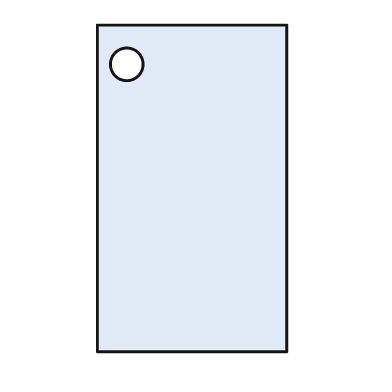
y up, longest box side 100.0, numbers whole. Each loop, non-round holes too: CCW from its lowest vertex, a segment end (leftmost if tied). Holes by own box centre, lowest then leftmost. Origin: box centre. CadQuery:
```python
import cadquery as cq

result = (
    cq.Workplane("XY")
    .moveTo(-29.0, -50.0)
    .lineTo(29.0, -50.0)
    .lineTo(29.0, 50.0)
    .lineTo(-29.0, 50.0)
    .close()
    .moveTo(-20.0, 38.0)
    .circle(5.0)
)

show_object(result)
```